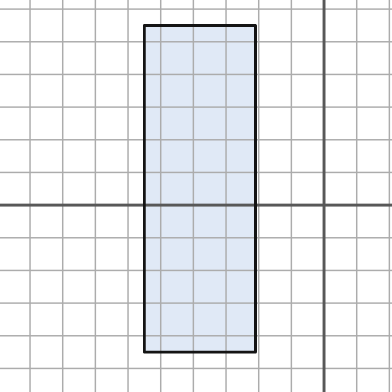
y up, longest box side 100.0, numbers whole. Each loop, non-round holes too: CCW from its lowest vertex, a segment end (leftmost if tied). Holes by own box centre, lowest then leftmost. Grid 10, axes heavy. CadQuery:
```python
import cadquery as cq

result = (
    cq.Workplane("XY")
    .moveTo(-55.0, -45.0)
    .lineTo(-21.0, -45.0)
    .lineTo(-21.0, 55.0)
    .lineTo(-55.0, 55.0)
    .close()
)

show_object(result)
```